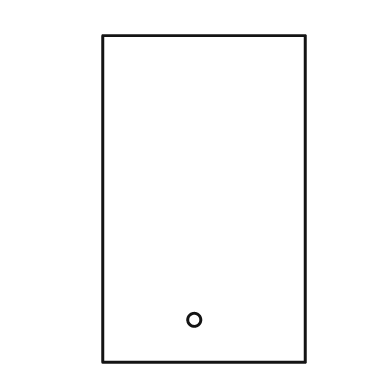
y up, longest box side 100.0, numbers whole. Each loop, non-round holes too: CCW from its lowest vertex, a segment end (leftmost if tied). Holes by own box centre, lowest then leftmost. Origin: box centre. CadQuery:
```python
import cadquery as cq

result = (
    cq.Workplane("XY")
    .moveTo(-31.0, -50.0)
    .lineTo(31.0, -50.0)
    .lineTo(31.0, 50.0)
    .lineTo(-31.0, 50.0)
    .close()
    .moveTo(-3.0, -37.0)
    .circle(2.0)
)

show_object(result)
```